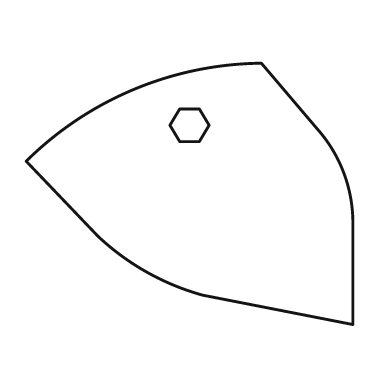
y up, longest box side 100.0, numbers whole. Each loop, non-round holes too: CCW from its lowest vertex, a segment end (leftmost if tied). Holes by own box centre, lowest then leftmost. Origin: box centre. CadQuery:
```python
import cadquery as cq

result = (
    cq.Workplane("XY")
    .moveTo(50.0, -40.0)
    .lineTo(50.0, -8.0)
    .threePointArc((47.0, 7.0), (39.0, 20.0))
    .lineTo(22.0, 40.0)
    .threePointArc((-17.0, 32.0), (-50.0, 10.0))
    .lineTo(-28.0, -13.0)
    .threePointArc((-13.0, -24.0), (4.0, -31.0))
    .close()
    .moveTo(-3.0, 16.0)
    .lineTo(3.0, 16.0)
    .lineTo(6.0, 21.0)
    .lineTo(3.0, 26.0)
    .lineTo(-3.0, 26.0)
    .lineTo(-6.0, 21.0)
    .close()
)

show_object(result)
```